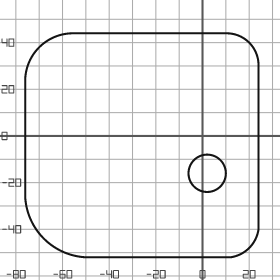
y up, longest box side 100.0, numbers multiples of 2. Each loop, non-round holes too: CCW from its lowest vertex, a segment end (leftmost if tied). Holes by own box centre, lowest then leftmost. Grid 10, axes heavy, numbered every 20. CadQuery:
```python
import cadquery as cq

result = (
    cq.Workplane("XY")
    .moveTo(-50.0, -52.0)
    .lineTo(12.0, -52.0)
    .threePointArc((20.0, -48.0), (24.0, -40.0))
    .lineTo(24.0, 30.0)
    .threePointArc((20.0, 40.0), (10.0, 44.0))
    .lineTo(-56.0, 44.0)
    .threePointArc((-70.0, 38.0), (-76.0, 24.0))
    .lineTo(-76.0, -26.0)
    .threePointArc((-68.0, -44.0), (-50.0, -52.0))
    .close()
    .moveTo(2.0, -16.0)
    .circle(8.0)
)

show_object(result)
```